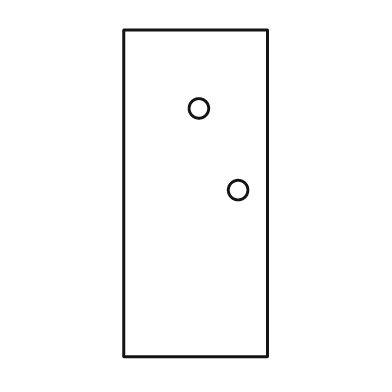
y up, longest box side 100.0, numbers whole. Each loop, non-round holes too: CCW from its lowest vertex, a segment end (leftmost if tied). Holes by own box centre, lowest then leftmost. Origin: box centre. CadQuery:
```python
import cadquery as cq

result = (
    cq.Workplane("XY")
    .moveTo(-22.0, -50.0)
    .lineTo(22.0, -50.0)
    .lineTo(22.0, 50.0)
    .lineTo(-22.0, 50.0)
    .close()
    .moveTo(13.0, 1.0)
    .circle(3.0)
    .moveTo(1.0, 26.0)
    .circle(3.0)
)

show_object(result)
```